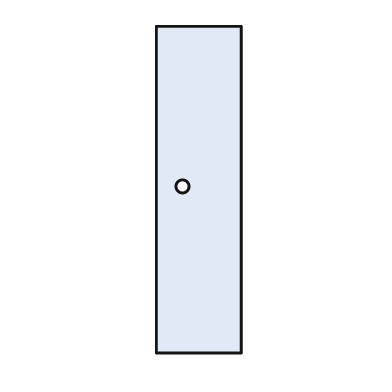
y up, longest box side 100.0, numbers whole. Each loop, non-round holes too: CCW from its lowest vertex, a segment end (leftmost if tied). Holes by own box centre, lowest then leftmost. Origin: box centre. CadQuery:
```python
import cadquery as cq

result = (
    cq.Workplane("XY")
    .moveTo(-13.0, -50.0)
    .lineTo(13.0, -50.0)
    .lineTo(13.0, 50.0)
    .lineTo(-13.0, 50.0)
    .close()
    .moveTo(-5.0, 1.0)
    .circle(2.0)
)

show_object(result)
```